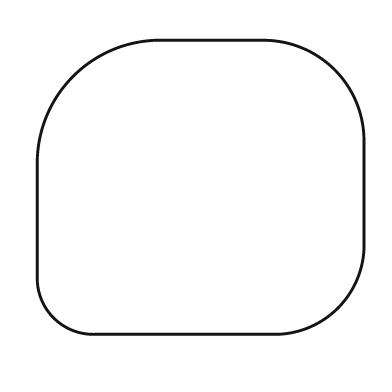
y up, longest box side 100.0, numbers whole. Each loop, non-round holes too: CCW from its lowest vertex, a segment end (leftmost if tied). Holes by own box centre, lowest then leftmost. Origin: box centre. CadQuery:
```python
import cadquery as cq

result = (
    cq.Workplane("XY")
    .moveTo(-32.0, -45.0)
    .lineTo(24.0, -45.0)
    .threePointArc((42.0, -37.0), (50.0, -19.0))
    .lineTo(50.0, 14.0)
    .threePointArc((41.0, 36.0), (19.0, 45.0))
    .lineTo(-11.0, 45.0)
    .threePointArc((-39.0, 34.0), (-50.0, 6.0))
    .lineTo(-50.0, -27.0)
    .threePointArc((-45.0, -40.0), (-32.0, -45.0))
    .close()
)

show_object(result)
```